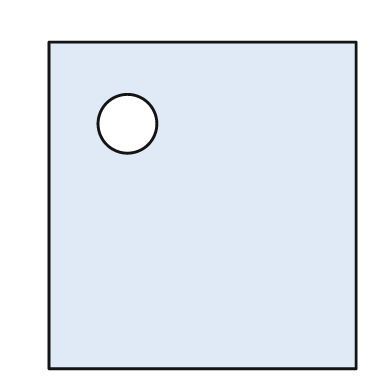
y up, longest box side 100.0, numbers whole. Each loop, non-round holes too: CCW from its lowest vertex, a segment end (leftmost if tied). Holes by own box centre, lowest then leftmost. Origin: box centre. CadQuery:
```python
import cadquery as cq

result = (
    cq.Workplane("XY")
    .moveTo(-47.0, -50.0)
    .lineTo(47.0, -50.0)
    .lineTo(47.0, 50.0)
    .lineTo(-47.0, 50.0)
    .close()
    .moveTo(-23.0, 25.0)
    .circle(9.0)
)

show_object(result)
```